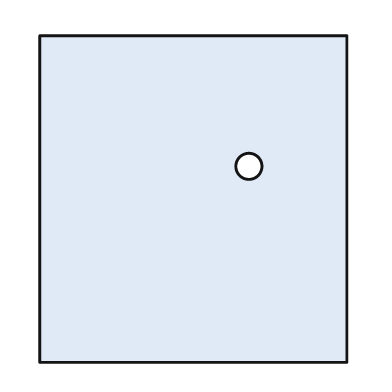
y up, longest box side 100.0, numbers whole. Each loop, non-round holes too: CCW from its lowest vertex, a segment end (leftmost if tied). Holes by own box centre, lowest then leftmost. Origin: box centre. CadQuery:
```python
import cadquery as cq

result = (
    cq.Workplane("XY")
    .moveTo(-47.0, -50.0)
    .lineTo(47.0, -50.0)
    .lineTo(47.0, 50.0)
    .lineTo(-47.0, 50.0)
    .close()
    .moveTo(17.0, 10.0)
    .circle(4.0)
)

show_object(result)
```